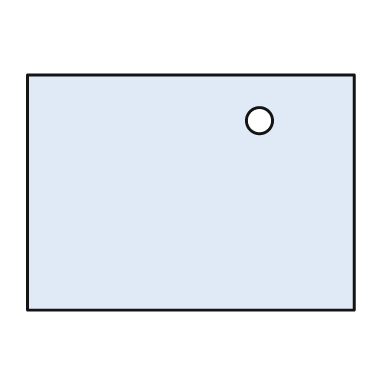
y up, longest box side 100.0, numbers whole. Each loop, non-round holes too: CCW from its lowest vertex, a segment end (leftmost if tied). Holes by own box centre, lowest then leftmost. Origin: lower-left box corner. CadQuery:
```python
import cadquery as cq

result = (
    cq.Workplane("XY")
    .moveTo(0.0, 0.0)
    .lineTo(100.0, 0.0)
    .lineTo(100.0, 72.0)
    .lineTo(0.0, 72.0)
    .close()
    .moveTo(71.0, 58.0)
    .circle(4.0)
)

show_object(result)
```